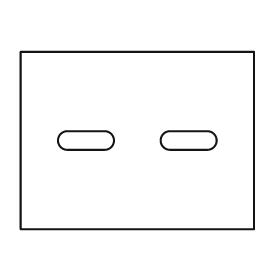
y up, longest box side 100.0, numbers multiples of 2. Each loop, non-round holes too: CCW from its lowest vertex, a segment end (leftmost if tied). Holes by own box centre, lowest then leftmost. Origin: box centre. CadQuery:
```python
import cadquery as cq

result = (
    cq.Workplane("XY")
    .moveTo(-50.0, -38.0)
    .lineTo(50.0, -38.0)
    .lineTo(50.0, 38.0)
    .lineTo(-50.0, 38.0)
    .close()
    .moveTo(-30.0, -4.0)
    .lineTo(-14.0, -4.0)
    .threePointArc((-10.0, 0.0), (-14.0, 4.0))
    .lineTo(-30.0, 4.0)
    .threePointArc((-34.0, 0.0), (-30.0, -4.0))
    .close()
    .moveTo(14.0, -4.0)
    .lineTo(30.0, -4.0)
    .threePointArc((34.0, 0.0), (30.0, 4.0))
    .lineTo(14.0, 4.0)
    .threePointArc((10.0, 0.0), (14.0, -4.0))
    .close()
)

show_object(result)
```